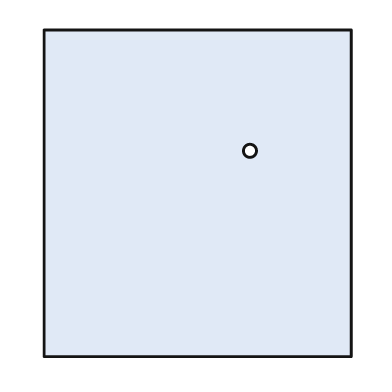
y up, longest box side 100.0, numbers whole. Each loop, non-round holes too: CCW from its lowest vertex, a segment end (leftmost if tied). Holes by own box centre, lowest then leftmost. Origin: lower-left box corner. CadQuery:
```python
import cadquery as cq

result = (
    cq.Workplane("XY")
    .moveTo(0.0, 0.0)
    .lineTo(94.0, 0.0)
    .lineTo(94.0, 100.0)
    .lineTo(0.0, 100.0)
    .close()
    .moveTo(63.0, 63.0)
    .circle(2.0)
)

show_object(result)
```